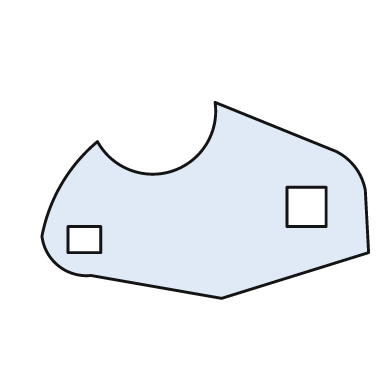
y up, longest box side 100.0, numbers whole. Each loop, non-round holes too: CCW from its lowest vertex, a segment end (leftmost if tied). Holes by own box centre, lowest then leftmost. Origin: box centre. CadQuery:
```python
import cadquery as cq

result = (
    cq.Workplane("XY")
    .moveTo(5.0, -30.0)
    .lineTo(50.0, -16.0)
    .lineTo(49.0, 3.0)
    .threePointArc((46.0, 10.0), (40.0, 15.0))
    .lineTo(3.0, 30.0)
    .threePointArc((-10.0, 9.0), (-33.0, 18.0))
    .threePointArc((-44.0, 5.0), (-50.0, -11.0))
    .threePointArc((-45.0, -20.0), (-35.0, -23.0))
    .close()
    .moveTo(-42.0, -16.0)
    .lineTo(-32.0, -16.0)
    .lineTo(-32.0, -8.0)
    .lineTo(-42.0, -8.0)
    .close()
    .moveTo(25.0, -8.0)
    .lineTo(37.0, -8.0)
    .lineTo(37.0, 4.0)
    .lineTo(25.0, 4.0)
    .close()
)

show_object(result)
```